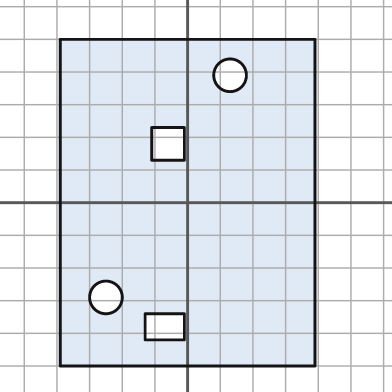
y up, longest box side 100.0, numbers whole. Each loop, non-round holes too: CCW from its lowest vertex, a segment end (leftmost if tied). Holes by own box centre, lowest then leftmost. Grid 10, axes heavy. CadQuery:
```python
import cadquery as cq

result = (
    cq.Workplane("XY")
    .moveTo(-39.0, -50.0)
    .lineTo(39.0, -50.0)
    .lineTo(39.0, 50.0)
    .lineTo(-39.0, 50.0)
    .close()
    .moveTo(-13.0, -42.0)
    .lineTo(-1.0, -42.0)
    .lineTo(-1.0, -34.0)
    .lineTo(-13.0, -34.0)
    .close()
    .moveTo(-25.0, -29.0)
    .circle(5.0)
    .moveTo(-11.0, 13.0)
    .lineTo(-1.0, 13.0)
    .lineTo(-1.0, 23.0)
    .lineTo(-11.0, 23.0)
    .close()
    .moveTo(13.0, 39.0)
    .circle(5.0)
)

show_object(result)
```